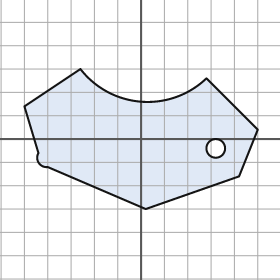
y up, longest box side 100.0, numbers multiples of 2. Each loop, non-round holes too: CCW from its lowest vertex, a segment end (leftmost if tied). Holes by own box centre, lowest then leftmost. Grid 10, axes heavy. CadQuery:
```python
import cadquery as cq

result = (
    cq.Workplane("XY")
    .moveTo(2.0, -30.0)
    .lineTo(42.0, -16.0)
    .lineTo(50.0, 4.0)
    .lineTo(28.0, 26.0)
    .threePointArc((0.0, 16.0), (-26.0, 30.0))
    .lineTo(-50.0, 14.0)
    .lineTo(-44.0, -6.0)
    .threePointArc((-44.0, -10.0), (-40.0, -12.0))
    .close()
    .moveTo(32.0, -4.0)
    .circle(4.0)
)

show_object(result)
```